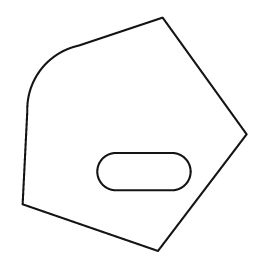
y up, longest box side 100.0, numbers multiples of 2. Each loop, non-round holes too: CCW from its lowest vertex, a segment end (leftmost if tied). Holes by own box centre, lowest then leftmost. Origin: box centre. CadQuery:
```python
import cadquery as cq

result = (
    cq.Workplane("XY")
    .moveTo(10.0, -50.0)
    .lineTo(48.0, 0.0)
    .lineTo(12.0, 50.0)
    .lineTo(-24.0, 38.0)
    .threePointArc((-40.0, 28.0), (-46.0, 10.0))
    .lineTo(-48.0, -30.0)
    .close()
    .moveTo(-8.0, -24.0)
    .lineTo(16.0, -24.0)
    .threePointArc((24.0, -16.0), (16.0, -8.0))
    .lineTo(-8.0, -8.0)
    .threePointArc((-16.0, -16.0), (-8.0, -24.0))
    .close()
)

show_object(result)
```